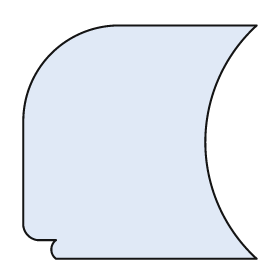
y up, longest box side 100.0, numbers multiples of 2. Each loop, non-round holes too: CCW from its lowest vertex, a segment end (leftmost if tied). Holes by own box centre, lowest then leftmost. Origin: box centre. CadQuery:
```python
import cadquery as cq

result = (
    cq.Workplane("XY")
    .moveTo(-36.0, -50.0)
    .lineTo(50.0, -50.0)
    .threePointArc((28.0, 0.0), (50.0, 50.0))
    .lineTo(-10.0, 50.0)
    .threePointArc((-38.0, 38.0), (-50.0, 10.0))
    .lineTo(-50.0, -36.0)
    .threePointArc((-48.0, -40.0), (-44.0, -42.0))
    .lineTo(-36.0, -42.0)
    .threePointArc((-38.0, -46.0), (-36.0, -50.0))
    .close()
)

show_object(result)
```